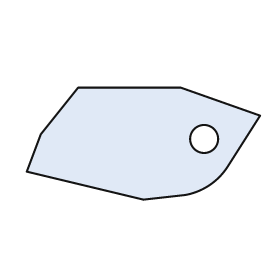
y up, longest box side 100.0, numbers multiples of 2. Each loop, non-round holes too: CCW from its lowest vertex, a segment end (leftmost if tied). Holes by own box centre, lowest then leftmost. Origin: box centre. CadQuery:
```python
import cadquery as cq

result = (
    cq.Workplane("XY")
    .moveTo(0.0, -24.0)
    .lineTo(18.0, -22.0)
    .threePointArc((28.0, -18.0), (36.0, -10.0))
    .lineTo(50.0, 12.0)
    .lineTo(16.0, 24.0)
    .lineTo(-28.0, 24.0)
    .lineTo(-44.0, 4.0)
    .lineTo(-50.0, -12.0)
    .close()
    .moveTo(26.0, 2.0)
    .circle(6.0)
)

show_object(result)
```